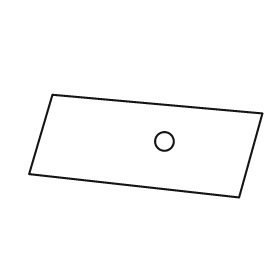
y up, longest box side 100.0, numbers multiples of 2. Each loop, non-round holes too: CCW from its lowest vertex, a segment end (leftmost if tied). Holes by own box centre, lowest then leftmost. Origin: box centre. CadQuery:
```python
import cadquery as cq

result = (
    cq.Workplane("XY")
    .moveTo(40.0, -22.0)
    .lineTo(50.0, 14.0)
    .lineTo(-40.0, 22.0)
    .lineTo(-50.0, -12.0)
    .close()
    .moveTo(8.0, 2.0)
    .circle(4.0)
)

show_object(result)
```